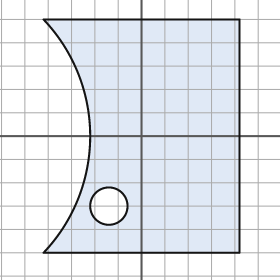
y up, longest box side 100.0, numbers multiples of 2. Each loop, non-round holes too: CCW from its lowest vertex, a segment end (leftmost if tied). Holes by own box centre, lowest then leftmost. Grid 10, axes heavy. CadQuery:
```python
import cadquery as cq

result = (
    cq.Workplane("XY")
    .moveTo(-42.0, -50.0)
    .lineTo(42.0, -50.0)
    .lineTo(42.0, 50.0)
    .lineTo(-42.0, 50.0)
    .threePointArc((-22.0, 0.0), (-42.0, -50.0))
    .close()
    .moveTo(-14.0, -30.0)
    .circle(8.0)
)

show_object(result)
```